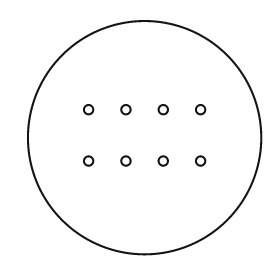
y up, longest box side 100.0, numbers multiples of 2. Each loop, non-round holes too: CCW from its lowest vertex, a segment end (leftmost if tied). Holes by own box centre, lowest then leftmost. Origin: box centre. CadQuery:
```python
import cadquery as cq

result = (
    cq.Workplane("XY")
    .moveTo(0.0, 0.0)
    .circle(50.0)
    .moveTo(-24.0, -10.0)
    .circle(2.0)
    .moveTo(-8.0, -10.0)
    .circle(2.0)
    .moveTo(8.0, -10.0)
    .circle(2.0)
    .moveTo(24.0, -10.0)
    .circle(2.0)
    .moveTo(-24.0, 12.0)
    .circle(2.0)
    .moveTo(-8.0, 12.0)
    .circle(2.0)
    .moveTo(8.0, 12.0)
    .circle(2.0)
    .moveTo(24.0, 12.0)
    .circle(2.0)
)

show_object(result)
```